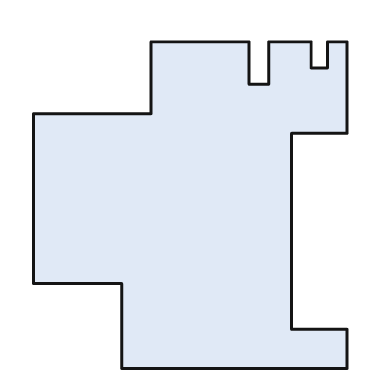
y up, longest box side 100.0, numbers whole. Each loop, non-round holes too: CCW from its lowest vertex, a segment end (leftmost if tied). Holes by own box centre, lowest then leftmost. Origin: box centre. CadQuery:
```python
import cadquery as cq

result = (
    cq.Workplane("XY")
    .moveTo(-21.0, -50.0)
    .lineTo(48.0, -50.0)
    .lineTo(48.0, -38.0)
    .lineTo(31.0, -38.0)
    .lineTo(31.0, 22.0)
    .lineTo(48.0, 22.0)
    .lineTo(48.0, 50.0)
    .lineTo(42.0, 50.0)
    .lineTo(42.0, 42.0)
    .lineTo(37.0, 42.0)
    .lineTo(37.0, 50.0)
    .lineTo(24.0, 50.0)
    .lineTo(24.0, 37.0)
    .lineTo(18.0, 37.0)
    .lineTo(18.0, 50.0)
    .lineTo(-12.0, 50.0)
    .lineTo(-12.0, 28.0)
    .lineTo(-48.0, 28.0)
    .lineTo(-48.0, -24.0)
    .lineTo(-21.0, -24.0)
    .close()
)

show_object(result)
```